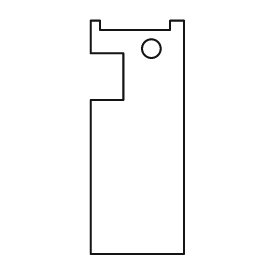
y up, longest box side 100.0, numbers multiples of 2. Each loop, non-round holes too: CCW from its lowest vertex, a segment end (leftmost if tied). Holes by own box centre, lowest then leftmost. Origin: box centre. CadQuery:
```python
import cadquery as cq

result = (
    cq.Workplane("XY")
    .moveTo(-20.0, -50.0)
    .lineTo(20.0, -50.0)
    .lineTo(20.0, 50.0)
    .lineTo(14.0, 50.0)
    .lineTo(14.0, 46.0)
    .lineTo(-16.0, 46.0)
    .lineTo(-16.0, 50.0)
    .lineTo(-20.0, 50.0)
    .lineTo(-20.0, 36.0)
    .lineTo(-6.0, 36.0)
    .lineTo(-6.0, 16.0)
    .lineTo(-20.0, 16.0)
    .close()
    .moveTo(6.0, 38.0)
    .circle(4.0)
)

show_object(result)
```